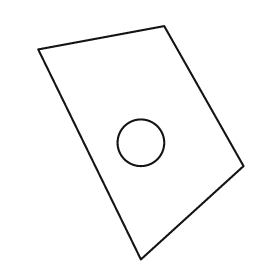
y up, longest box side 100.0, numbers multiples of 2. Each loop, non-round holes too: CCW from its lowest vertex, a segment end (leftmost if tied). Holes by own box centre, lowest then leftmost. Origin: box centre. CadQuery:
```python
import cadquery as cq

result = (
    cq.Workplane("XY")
    .moveTo(0.0, -50.0)
    .lineTo(44.0, -10.0)
    .lineTo(10.0, 50.0)
    .lineTo(-44.0, 40.0)
    .close()
    .moveTo(0.0, 0.0)
    .circle(10.0)
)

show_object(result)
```